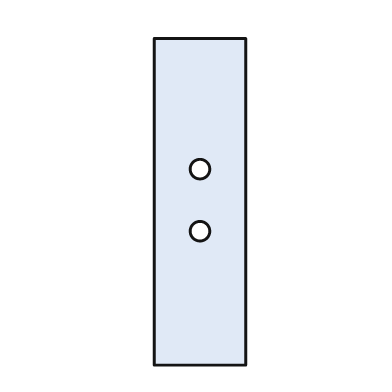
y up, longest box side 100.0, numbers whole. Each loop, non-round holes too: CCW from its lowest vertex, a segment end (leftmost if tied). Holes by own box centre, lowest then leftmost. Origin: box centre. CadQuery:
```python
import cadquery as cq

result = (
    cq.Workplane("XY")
    .moveTo(-14.0, -50.0)
    .lineTo(14.0, -50.0)
    .lineTo(14.0, 50.0)
    .lineTo(-14.0, 50.0)
    .close()
    .moveTo(0.0, -9.0)
    .circle(3.0)
    .moveTo(0.0, 10.0)
    .circle(3.0)
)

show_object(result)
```